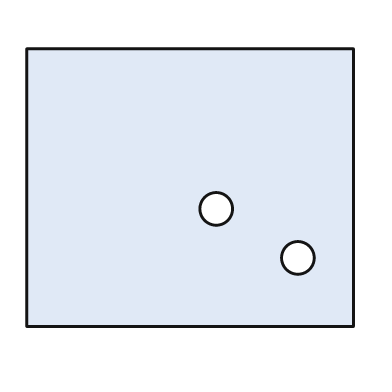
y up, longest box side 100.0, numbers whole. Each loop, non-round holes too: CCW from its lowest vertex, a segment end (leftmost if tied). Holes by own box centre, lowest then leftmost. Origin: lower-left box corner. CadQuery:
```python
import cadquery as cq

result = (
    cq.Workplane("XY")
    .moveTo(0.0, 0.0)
    .lineTo(100.0, 0.0)
    .lineTo(100.0, 85.0)
    .lineTo(0.0, 85.0)
    .close()
    .moveTo(83.0, 21.0)
    .circle(5.0)
    .moveTo(58.0, 36.0)
    .circle(5.0)
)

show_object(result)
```